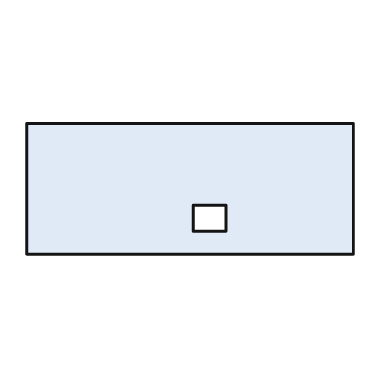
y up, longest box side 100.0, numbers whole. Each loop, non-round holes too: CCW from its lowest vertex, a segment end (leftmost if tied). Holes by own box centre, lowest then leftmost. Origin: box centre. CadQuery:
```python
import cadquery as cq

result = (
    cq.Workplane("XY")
    .moveTo(-50.0, -20.0)
    .lineTo(50.0, -20.0)
    .lineTo(50.0, 20.0)
    .lineTo(-50.0, 20.0)
    .close()
    .moveTo(1.0, -13.0)
    .lineTo(11.0, -13.0)
    .lineTo(11.0, -5.0)
    .lineTo(1.0, -5.0)
    .close()
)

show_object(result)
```